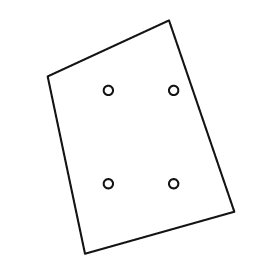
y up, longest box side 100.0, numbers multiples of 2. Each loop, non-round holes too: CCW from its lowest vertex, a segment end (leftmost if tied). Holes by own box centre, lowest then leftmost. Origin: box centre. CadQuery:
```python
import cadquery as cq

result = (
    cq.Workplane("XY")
    .moveTo(-24.0, -50.0)
    .lineTo(40.0, -32.0)
    .lineTo(12.0, 50.0)
    .lineTo(-40.0, 26.0)
    .close()
    .moveTo(-14.0, -20.0)
    .circle(2.0)
    .moveTo(14.0, -20.0)
    .circle(2.0)
    .moveTo(-14.0, 20.0)
    .circle(2.0)
    .moveTo(14.0, 20.0)
    .circle(2.0)
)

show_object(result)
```